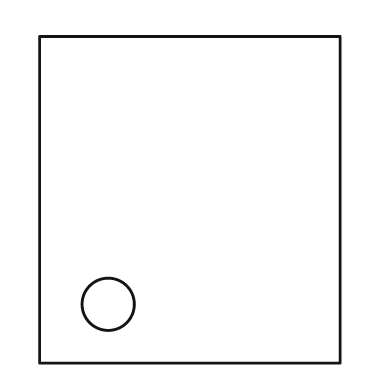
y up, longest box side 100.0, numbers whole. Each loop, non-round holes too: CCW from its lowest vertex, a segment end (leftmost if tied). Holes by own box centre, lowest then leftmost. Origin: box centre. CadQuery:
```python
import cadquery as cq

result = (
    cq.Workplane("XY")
    .moveTo(-46.0, -50.0)
    .lineTo(46.0, -50.0)
    .lineTo(46.0, 50.0)
    .lineTo(-46.0, 50.0)
    .close()
    .moveTo(-25.0, -32.0)
    .circle(8.0)
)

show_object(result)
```